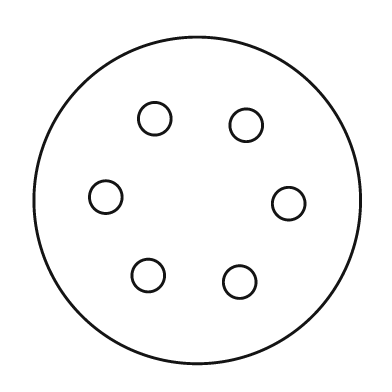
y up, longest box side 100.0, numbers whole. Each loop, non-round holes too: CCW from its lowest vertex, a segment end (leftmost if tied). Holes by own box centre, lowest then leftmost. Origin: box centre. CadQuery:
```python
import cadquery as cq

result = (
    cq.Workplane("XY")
    .moveTo(0.0, 0.0)
    .circle(50.0)
    .moveTo(13.0, -25.0)
    .circle(5.0)
    .moveTo(-15.0, -23.0)
    .circle(5.0)
    .moveTo(28.0, -1.0)
    .circle(5.0)
    .moveTo(-28.0, 1.0)
    .circle(5.0)
    .moveTo(15.0, 23.0)
    .circle(5.0)
    .moveTo(-13.0, 25.0)
    .circle(5.0)
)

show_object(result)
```